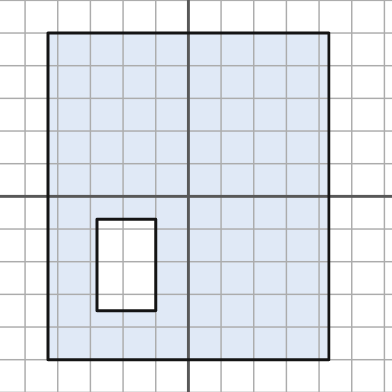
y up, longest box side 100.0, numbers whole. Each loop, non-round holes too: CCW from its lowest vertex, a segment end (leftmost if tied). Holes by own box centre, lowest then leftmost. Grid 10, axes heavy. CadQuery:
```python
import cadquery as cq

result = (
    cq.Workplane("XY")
    .moveTo(-43.0, -50.0)
    .lineTo(43.0, -50.0)
    .lineTo(43.0, 50.0)
    .lineTo(-43.0, 50.0)
    .close()
    .moveTo(-28.0, -35.0)
    .lineTo(-10.0, -35.0)
    .lineTo(-10.0, -7.0)
    .lineTo(-28.0, -7.0)
    .close()
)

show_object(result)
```